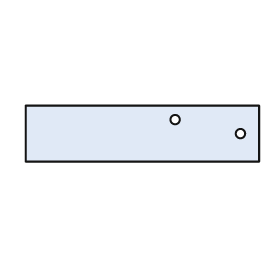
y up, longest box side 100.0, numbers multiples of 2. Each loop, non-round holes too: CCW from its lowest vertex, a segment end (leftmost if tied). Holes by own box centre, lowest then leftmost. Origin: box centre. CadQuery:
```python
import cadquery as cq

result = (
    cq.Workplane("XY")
    .moveTo(-50.0, -12.0)
    .lineTo(50.0, -12.0)
    .lineTo(50.0, 12.0)
    .lineTo(-50.0, 12.0)
    .close()
    .moveTo(42.0, 0.0)
    .circle(2.0)
    .moveTo(14.0, 6.0)
    .circle(2.0)
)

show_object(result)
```